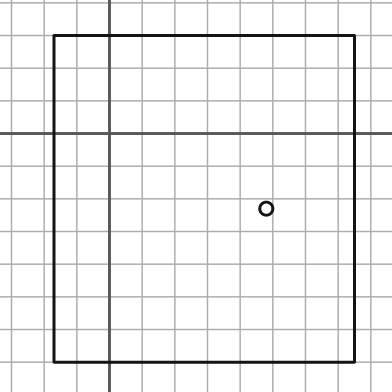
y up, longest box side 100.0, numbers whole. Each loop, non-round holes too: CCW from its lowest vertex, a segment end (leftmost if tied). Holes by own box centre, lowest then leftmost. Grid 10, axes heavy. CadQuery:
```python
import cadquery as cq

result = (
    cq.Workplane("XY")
    .moveTo(-17.0, -70.0)
    .lineTo(75.0, -70.0)
    .lineTo(75.0, 30.0)
    .lineTo(-17.0, 30.0)
    .close()
    .moveTo(48.0, -23.0)
    .circle(2.0)
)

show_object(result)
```